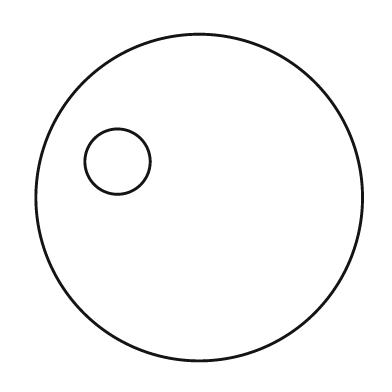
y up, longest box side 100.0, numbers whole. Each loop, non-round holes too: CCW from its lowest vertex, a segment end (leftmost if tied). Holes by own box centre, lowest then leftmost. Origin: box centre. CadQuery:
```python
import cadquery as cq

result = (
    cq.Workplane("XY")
    .moveTo(0.0, 0.0)
    .circle(50.0)
    .moveTo(-25.0, 11.0)
    .circle(10.0)
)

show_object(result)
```